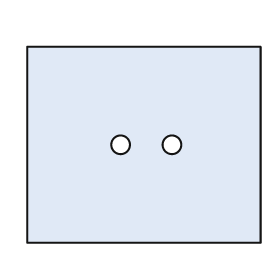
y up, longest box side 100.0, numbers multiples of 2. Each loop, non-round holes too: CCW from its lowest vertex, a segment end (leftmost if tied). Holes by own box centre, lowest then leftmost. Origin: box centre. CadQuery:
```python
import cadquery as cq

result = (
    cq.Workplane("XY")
    .moveTo(-50.0, -42.0)
    .lineTo(50.0, -42.0)
    .lineTo(50.0, 42.0)
    .lineTo(-50.0, 42.0)
    .close()
    .moveTo(-10.0, 0.0)
    .circle(4.0)
    .moveTo(12.0, 0.0)
    .circle(4.0)
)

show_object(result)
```